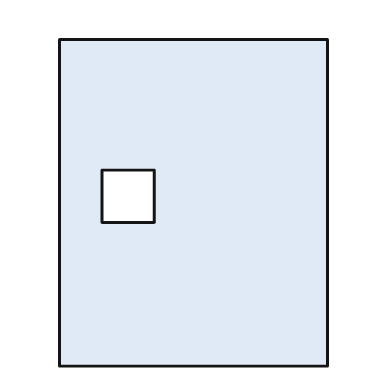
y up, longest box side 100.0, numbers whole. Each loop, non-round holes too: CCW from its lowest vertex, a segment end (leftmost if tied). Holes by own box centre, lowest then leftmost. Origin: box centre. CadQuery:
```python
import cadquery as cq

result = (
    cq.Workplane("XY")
    .moveTo(-41.0, -50.0)
    .lineTo(41.0, -50.0)
    .lineTo(41.0, 50.0)
    .lineTo(-41.0, 50.0)
    .close()
    .moveTo(-28.0, -6.0)
    .lineTo(-12.0, -6.0)
    .lineTo(-12.0, 10.0)
    .lineTo(-28.0, 10.0)
    .close()
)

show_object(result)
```